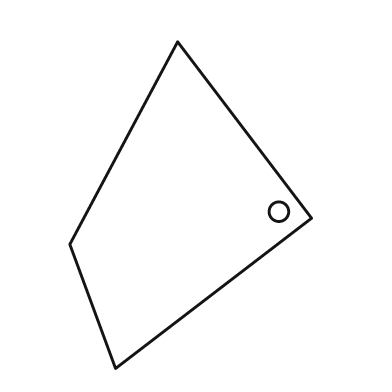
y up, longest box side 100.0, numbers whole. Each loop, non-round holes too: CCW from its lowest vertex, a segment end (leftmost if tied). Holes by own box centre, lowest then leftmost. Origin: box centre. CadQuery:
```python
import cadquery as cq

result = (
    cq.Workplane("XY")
    .moveTo(-23.0, -50.0)
    .lineTo(37.0, -4.0)
    .lineTo(-4.0, 50.0)
    .lineTo(-37.0, -12.0)
    .close()
    .moveTo(27.0, -2.0)
    .circle(3.0)
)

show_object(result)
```